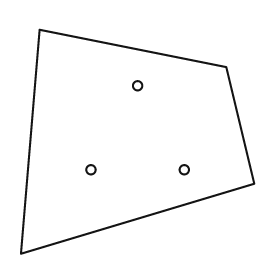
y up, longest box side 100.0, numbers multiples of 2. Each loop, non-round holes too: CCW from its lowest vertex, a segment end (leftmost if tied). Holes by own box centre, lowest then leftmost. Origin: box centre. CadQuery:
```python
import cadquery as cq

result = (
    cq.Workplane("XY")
    .moveTo(-50.0, -48.0)
    .lineTo(50.0, -18.0)
    .lineTo(38.0, 32.0)
    .lineTo(-42.0, 48.0)
    .close()
    .moveTo(-20.0, -12.0)
    .circle(2.0)
    .moveTo(20.0, -12.0)
    .circle(2.0)
    .moveTo(0.0, 24.0)
    .circle(2.0)
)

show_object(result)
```